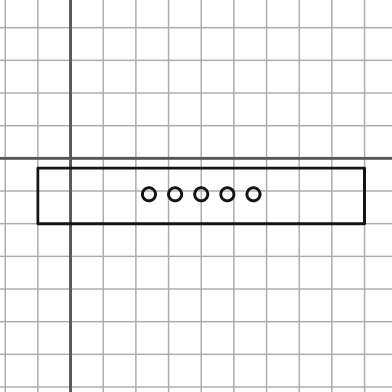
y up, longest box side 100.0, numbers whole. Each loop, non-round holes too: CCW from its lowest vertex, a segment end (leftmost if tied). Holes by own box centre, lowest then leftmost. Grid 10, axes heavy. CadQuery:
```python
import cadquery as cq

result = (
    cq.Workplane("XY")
    .moveTo(-10.0, -20.0)
    .lineTo(90.0, -20.0)
    .lineTo(90.0, -3.0)
    .lineTo(-10.0, -3.0)
    .close()
    .moveTo(24.0, -11.0)
    .circle(2.0)
    .moveTo(32.0, -11.0)
    .circle(2.0)
    .moveTo(40.0, -11.0)
    .circle(2.0)
    .moveTo(48.0, -11.0)
    .circle(2.0)
    .moveTo(56.0, -11.0)
    .circle(2.0)
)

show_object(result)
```